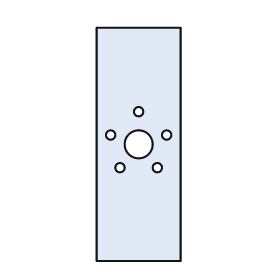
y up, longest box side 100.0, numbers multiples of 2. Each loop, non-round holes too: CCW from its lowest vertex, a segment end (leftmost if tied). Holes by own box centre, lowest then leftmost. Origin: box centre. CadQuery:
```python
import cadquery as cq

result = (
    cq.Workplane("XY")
    .moveTo(-18.0, -50.0)
    .lineTo(18.0, -50.0)
    .lineTo(18.0, 50.0)
    .lineTo(-18.0, 50.0)
    .close()
    .moveTo(-8.0, -10.0)
    .circle(2.0)
    .moveTo(8.0, -10.0)
    .circle(2.0)
    .moveTo(0.0, 0.0)
    .circle(6.0)
    .moveTo(-12.0, 4.0)
    .circle(2.0)
    .moveTo(12.0, 4.0)
    .circle(2.0)
    .moveTo(0.0, 14.0)
    .circle(2.0)
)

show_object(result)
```